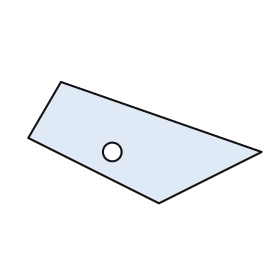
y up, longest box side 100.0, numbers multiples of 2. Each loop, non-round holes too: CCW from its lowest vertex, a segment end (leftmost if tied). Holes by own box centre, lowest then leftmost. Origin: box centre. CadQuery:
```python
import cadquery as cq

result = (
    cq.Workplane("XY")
    .moveTo(6.0, -26.0)
    .lineTo(50.0, -4.0)
    .lineTo(-36.0, 26.0)
    .lineTo(-50.0, 2.0)
    .close()
    .moveTo(-14.0, -4.0)
    .circle(4.0)
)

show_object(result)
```